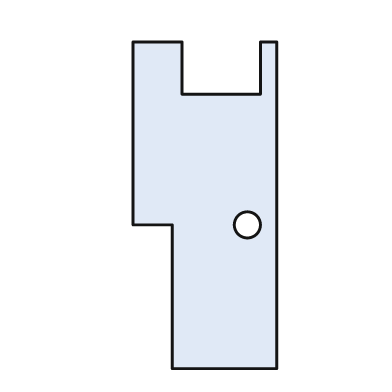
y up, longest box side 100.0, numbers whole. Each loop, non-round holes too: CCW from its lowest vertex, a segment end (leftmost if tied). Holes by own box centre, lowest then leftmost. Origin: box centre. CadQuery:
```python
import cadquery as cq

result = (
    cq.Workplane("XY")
    .moveTo(-10.0, -50.0)
    .lineTo(22.0, -50.0)
    .lineTo(22.0, 50.0)
    .lineTo(17.0, 50.0)
    .lineTo(17.0, 34.0)
    .lineTo(-7.0, 34.0)
    .lineTo(-7.0, 50.0)
    .lineTo(-22.0, 50.0)
    .lineTo(-22.0, -6.0)
    .lineTo(-10.0, -6.0)
    .close()
    .moveTo(13.0, -6.0)
    .circle(4.0)
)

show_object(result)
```